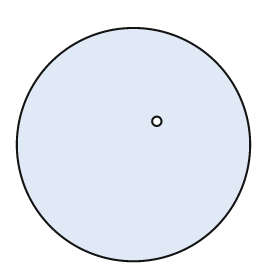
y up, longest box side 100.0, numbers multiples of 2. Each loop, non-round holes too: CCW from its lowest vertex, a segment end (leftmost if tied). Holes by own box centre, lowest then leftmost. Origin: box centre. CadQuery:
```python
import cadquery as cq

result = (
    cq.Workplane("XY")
    .moveTo(0.0, 0.0)
    .circle(50.0)
    .moveTo(10.0, 10.0)
    .circle(2.0)
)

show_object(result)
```